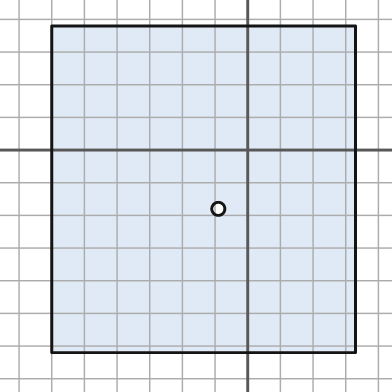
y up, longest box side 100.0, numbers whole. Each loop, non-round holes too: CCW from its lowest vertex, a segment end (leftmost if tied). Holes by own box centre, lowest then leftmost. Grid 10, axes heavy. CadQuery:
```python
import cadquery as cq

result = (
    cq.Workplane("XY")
    .moveTo(-60.0, -62.0)
    .lineTo(33.0, -62.0)
    .lineTo(33.0, 38.0)
    .lineTo(-60.0, 38.0)
    .close()
    .moveTo(-9.0, -18.0)
    .circle(2.0)
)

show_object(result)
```